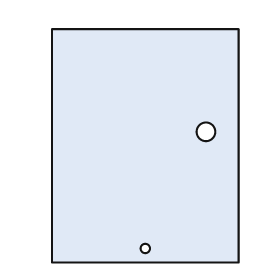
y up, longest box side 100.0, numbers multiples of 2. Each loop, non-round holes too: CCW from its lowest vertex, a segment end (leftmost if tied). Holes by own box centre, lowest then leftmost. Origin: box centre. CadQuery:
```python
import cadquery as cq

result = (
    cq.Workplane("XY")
    .moveTo(-40.0, -50.0)
    .lineTo(40.0, -50.0)
    .lineTo(40.0, 50.0)
    .lineTo(-40.0, 50.0)
    .close()
    .moveTo(0.0, -44.0)
    .circle(2.0)
    .moveTo(26.0, 6.0)
    .circle(4.0)
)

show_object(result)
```